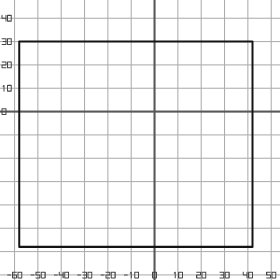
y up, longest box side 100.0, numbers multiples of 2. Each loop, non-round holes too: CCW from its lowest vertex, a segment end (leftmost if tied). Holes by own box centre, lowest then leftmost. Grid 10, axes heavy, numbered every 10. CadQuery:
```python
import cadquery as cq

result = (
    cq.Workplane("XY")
    .moveTo(-58.0, -58.0)
    .lineTo(42.0, -58.0)
    .lineTo(42.0, 30.0)
    .lineTo(-58.0, 30.0)
    .close()
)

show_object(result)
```